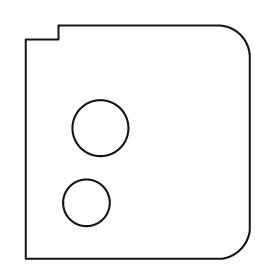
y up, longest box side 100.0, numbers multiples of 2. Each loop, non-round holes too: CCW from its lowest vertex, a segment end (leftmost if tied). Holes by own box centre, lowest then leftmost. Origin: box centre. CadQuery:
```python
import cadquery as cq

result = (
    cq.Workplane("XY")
    .moveTo(-48.0, -50.0)
    .lineTo(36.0, -50.0)
    .threePointArc((44.0, -46.0), (48.0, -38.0))
    .lineTo(48.0, 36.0)
    .threePointArc((44.0, 46.0), (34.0, 50.0))
    .lineTo(-34.0, 50.0)
    .lineTo(-34.0, 44.0)
    .lineTo(-48.0, 44.0)
    .close()
    .moveTo(-22.0, -26.0)
    .circle(10.0)
    .moveTo(-16.0, 6.0)
    .circle(12.0)
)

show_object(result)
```